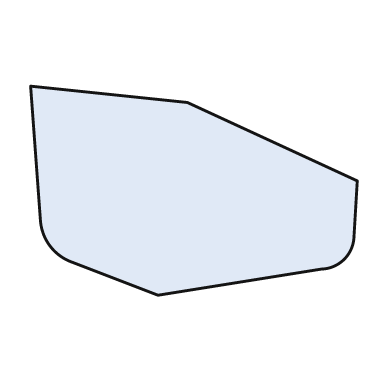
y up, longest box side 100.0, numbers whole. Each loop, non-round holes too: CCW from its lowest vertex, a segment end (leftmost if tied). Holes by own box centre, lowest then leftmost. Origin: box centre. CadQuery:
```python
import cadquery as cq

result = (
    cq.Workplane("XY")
    .moveTo(-11.0, -32.0)
    .lineTo(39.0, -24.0)
    .threePointArc((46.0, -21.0), (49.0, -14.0))
    .lineTo(50.0, 3.0)
    .lineTo(-2.0, 27.0)
    .lineTo(-50.0, 32.0)
    .lineTo(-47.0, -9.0)
    .threePointArc((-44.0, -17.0), (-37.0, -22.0))
    .close()
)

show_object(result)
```